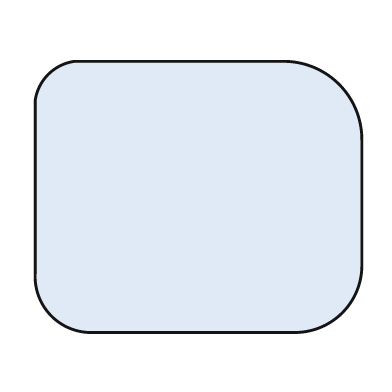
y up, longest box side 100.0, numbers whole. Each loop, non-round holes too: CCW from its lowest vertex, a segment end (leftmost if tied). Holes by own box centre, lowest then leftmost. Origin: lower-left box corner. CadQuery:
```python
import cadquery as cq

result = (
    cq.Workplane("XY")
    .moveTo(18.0, 0.0)
    .lineTo(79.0, 0.0)
    .threePointArc((94.0, 6.0), (100.0, 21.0))
    .lineTo(100.0, 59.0)
    .threePointArc((93.0, 76.0), (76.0, 83.0))
    .lineTo(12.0, 83.0)
    .threePointArc((4.0, 79.0), (0.0, 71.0))
    .lineTo(0.0, 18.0)
    .threePointArc((5.0, 5.0), (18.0, 0.0))
    .close()
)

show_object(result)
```